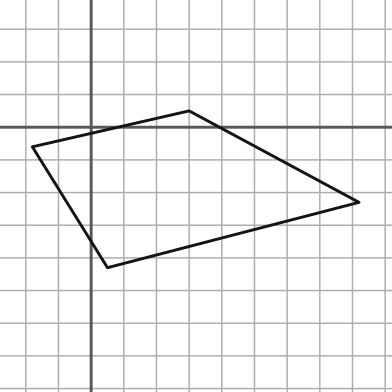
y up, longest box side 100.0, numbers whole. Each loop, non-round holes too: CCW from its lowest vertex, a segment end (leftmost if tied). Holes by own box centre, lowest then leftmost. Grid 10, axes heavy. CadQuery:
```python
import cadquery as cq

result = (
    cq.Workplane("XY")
    .moveTo(5.0, -43.0)
    .lineTo(82.0, -23.0)
    .lineTo(30.0, 5.0)
    .lineTo(-18.0, -6.0)
    .close()
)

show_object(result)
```